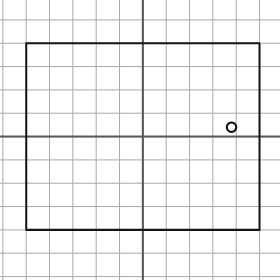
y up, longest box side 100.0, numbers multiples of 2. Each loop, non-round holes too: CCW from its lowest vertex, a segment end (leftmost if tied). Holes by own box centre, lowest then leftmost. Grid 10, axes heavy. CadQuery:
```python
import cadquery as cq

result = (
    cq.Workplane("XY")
    .moveTo(-50.0, -40.0)
    .lineTo(50.0, -40.0)
    .lineTo(50.0, 40.0)
    .lineTo(-50.0, 40.0)
    .close()
    .moveTo(38.0, 4.0)
    .circle(2.0)
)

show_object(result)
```